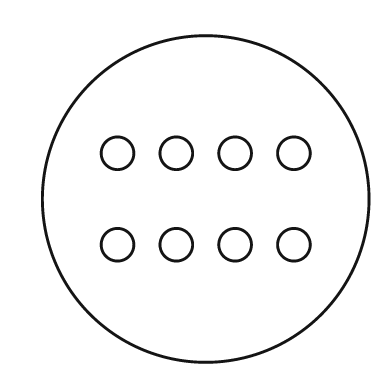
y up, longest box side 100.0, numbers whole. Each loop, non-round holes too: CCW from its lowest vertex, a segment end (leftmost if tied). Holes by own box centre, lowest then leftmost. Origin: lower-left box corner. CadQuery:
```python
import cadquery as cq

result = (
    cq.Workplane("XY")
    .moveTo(50.0, 50.0)
    .circle(50.0)
    .moveTo(23.0, 36.0)
    .circle(5.0)
    .moveTo(41.0, 36.0)
    .circle(5.0)
    .moveTo(59.0, 36.0)
    .circle(5.0)
    .moveTo(77.0, 36.0)
    .circle(5.0)
    .moveTo(23.0, 64.0)
    .circle(5.0)
    .moveTo(41.0, 64.0)
    .circle(5.0)
    .moveTo(59.0, 64.0)
    .circle(5.0)
    .moveTo(77.0, 64.0)
    .circle(5.0)
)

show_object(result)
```